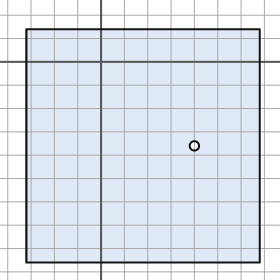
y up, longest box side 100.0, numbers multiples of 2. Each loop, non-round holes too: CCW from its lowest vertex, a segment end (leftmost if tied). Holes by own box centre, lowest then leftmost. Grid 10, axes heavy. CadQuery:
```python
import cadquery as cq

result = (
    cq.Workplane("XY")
    .moveTo(-32.0, -86.0)
    .lineTo(68.0, -86.0)
    .lineTo(68.0, 14.0)
    .lineTo(-32.0, 14.0)
    .close()
    .moveTo(40.0, -36.0)
    .circle(2.0)
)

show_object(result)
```